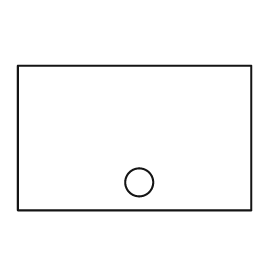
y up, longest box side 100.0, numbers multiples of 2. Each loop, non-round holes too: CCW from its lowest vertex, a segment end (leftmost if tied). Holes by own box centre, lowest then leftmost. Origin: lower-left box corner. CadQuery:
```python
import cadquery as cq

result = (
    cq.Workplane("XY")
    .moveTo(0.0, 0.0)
    .lineTo(100.0, 0.0)
    .lineTo(100.0, 62.0)
    .lineTo(0.0, 62.0)
    .close()
    .moveTo(52.0, 12.0)
    .circle(6.0)
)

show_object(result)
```